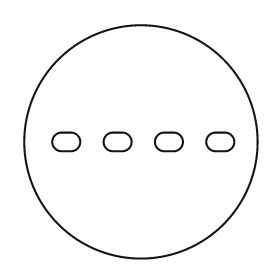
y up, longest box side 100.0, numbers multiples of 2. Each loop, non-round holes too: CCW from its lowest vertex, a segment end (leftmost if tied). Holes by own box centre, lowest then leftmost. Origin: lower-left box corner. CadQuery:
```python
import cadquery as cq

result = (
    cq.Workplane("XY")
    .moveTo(50.0, 50.0)
    .circle(50.0)
    .moveTo(16.0, 46.0)
    .lineTo(20.0, 46.0)
    .threePointArc((24.0, 50.0), (20.0, 54.0))
    .lineTo(16.0, 54.0)
    .threePointArc((12.0, 50.0), (16.0, 46.0))
    .close()
    .moveTo(38.0, 46.0)
    .lineTo(42.0, 46.0)
    .threePointArc((46.0, 50.0), (42.0, 54.0))
    .lineTo(38.0, 54.0)
    .threePointArc((34.0, 50.0), (38.0, 46.0))
    .close()
    .moveTo(60.0, 46.0)
    .lineTo(64.0, 46.0)
    .threePointArc((68.0, 50.0), (64.0, 54.0))
    .lineTo(60.0, 54.0)
    .threePointArc((56.0, 50.0), (60.0, 46.0))
    .close()
    .moveTo(82.0, 46.0)
    .lineTo(86.0, 46.0)
    .threePointArc((90.0, 50.0), (86.0, 54.0))
    .lineTo(82.0, 54.0)
    .threePointArc((78.0, 50.0), (82.0, 46.0))
    .close()
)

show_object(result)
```